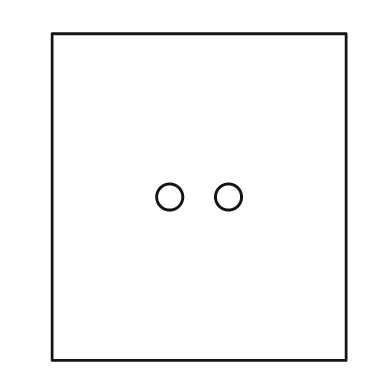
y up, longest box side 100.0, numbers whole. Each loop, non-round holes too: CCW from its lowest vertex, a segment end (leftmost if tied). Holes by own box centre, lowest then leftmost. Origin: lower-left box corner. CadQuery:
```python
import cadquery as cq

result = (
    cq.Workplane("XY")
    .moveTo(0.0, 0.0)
    .lineTo(90.0, 0.0)
    .lineTo(90.0, 100.0)
    .lineTo(0.0, 100.0)
    .close()
    .moveTo(36.0, 50.0)
    .circle(4.0)
    .moveTo(54.0, 50.0)
    .circle(4.0)
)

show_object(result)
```